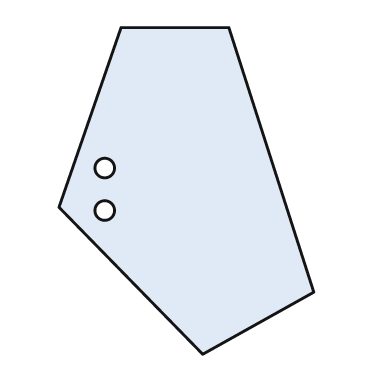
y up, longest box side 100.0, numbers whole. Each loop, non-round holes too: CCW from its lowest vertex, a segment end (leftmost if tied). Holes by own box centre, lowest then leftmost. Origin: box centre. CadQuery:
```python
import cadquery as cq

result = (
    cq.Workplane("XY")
    .moveTo(5.0, -50.0)
    .lineTo(39.0, -31.0)
    .lineTo(13.0, 50.0)
    .lineTo(-20.0, 50.0)
    .lineTo(-39.0, -5.0)
    .close()
    .moveTo(-25.0, -6.0)
    .circle(3.0)
    .moveTo(-25.0, 7.0)
    .circle(3.0)
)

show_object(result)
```